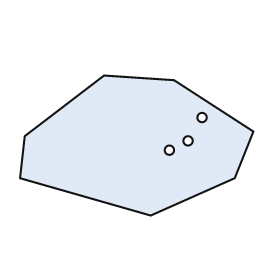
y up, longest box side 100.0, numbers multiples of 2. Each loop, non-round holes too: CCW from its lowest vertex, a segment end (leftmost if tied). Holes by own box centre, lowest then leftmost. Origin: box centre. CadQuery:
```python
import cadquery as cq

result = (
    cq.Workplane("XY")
    .moveTo(6.0, -30.0)
    .lineTo(42.0, -14.0)
    .lineTo(50.0, 6.0)
    .lineTo(16.0, 28.0)
    .lineTo(-14.0, 30.0)
    .lineTo(-48.0, 4.0)
    .lineTo(-50.0, -14.0)
    .close()
    .moveTo(14.0, -2.0)
    .circle(2.0)
    .moveTo(22.0, 2.0)
    .circle(2.0)
    .moveTo(28.0, 12.0)
    .circle(2.0)
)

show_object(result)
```